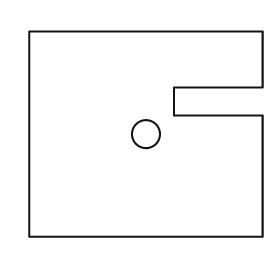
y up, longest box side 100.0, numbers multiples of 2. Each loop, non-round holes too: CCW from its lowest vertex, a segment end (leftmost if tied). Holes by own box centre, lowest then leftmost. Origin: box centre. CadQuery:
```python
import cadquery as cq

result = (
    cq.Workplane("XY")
    .moveTo(-50.0, -44.0)
    .lineTo(50.0, -44.0)
    .lineTo(50.0, 8.0)
    .lineTo(12.0, 8.0)
    .lineTo(12.0, 20.0)
    .lineTo(50.0, 20.0)
    .lineTo(50.0, 44.0)
    .lineTo(-50.0, 44.0)
    .close()
    .moveTo(0.0, 0.0)
    .circle(6.0)
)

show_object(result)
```